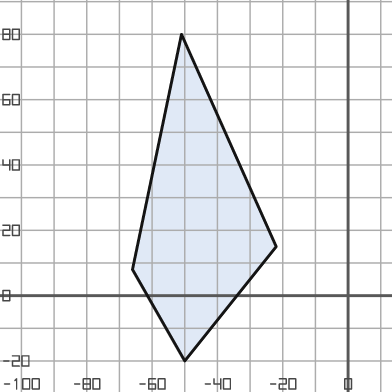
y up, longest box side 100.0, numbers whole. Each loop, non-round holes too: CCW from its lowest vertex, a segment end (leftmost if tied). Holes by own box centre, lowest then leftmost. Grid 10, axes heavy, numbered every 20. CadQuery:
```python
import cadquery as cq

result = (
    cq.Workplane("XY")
    .moveTo(-50.0, -20.0)
    .lineTo(-22.0, 15.0)
    .lineTo(-51.0, 80.0)
    .lineTo(-66.0, 8.0)
    .close()
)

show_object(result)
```